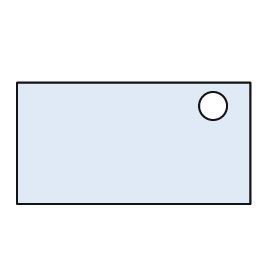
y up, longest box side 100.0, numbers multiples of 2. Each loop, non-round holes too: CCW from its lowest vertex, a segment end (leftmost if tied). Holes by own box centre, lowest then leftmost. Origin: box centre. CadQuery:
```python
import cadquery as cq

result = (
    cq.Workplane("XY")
    .moveTo(-50.0, -26.0)
    .lineTo(50.0, -26.0)
    .lineTo(50.0, 26.0)
    .lineTo(-50.0, 26.0)
    .close()
    .moveTo(34.0, 16.0)
    .circle(6.0)
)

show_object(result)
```